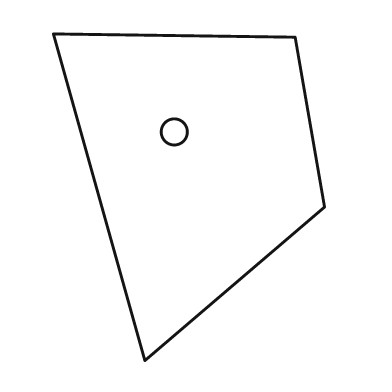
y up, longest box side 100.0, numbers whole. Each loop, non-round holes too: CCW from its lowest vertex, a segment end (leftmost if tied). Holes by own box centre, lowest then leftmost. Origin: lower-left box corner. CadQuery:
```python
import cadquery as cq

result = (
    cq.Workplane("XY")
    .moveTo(28.0, 0.0)
    .lineTo(83.0, 47.0)
    .lineTo(74.0, 99.0)
    .lineTo(0.0, 100.0)
    .close()
    .moveTo(37.0, 70.0)
    .circle(4.0)
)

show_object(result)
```